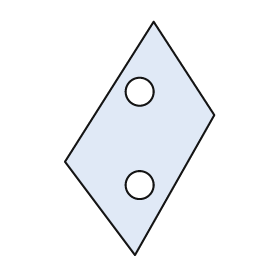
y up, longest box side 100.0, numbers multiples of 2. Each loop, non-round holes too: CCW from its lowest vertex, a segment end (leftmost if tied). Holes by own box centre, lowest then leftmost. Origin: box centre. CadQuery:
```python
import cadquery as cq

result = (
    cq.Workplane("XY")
    .moveTo(-2.0, -50.0)
    .lineTo(32.0, 10.0)
    .lineTo(6.0, 50.0)
    .lineTo(-32.0, -10.0)
    .close()
    .moveTo(0.0, -20.0)
    .circle(6.0)
    .moveTo(0.0, 20.0)
    .circle(6.0)
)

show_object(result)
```